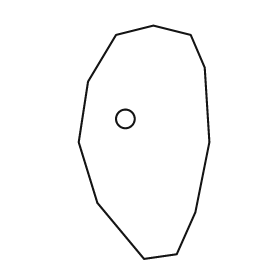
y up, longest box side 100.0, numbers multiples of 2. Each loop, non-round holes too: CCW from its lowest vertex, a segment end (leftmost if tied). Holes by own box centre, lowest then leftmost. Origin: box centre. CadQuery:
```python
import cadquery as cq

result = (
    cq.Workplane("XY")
    .moveTo(0.0, -50.0)
    .lineTo(14.0, -48.0)
    .lineTo(22.0, -30.0)
    .lineTo(28.0, 0.0)
    .lineTo(26.0, 32.0)
    .lineTo(20.0, 46.0)
    .lineTo(4.0, 50.0)
    .lineTo(-12.0, 46.0)
    .lineTo(-24.0, 26.0)
    .lineTo(-28.0, 0.0)
    .lineTo(-20.0, -26.0)
    .close()
    .moveTo(-8.0, 10.0)
    .circle(4.0)
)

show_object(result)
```